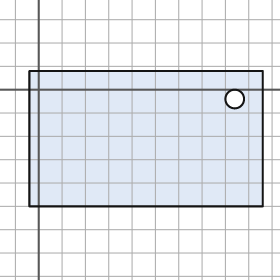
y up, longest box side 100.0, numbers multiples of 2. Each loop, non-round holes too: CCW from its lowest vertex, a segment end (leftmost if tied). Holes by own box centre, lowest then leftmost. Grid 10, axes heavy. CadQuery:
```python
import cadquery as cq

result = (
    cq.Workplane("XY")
    .moveTo(-4.0, -50.0)
    .lineTo(96.0, -50.0)
    .lineTo(96.0, 8.0)
    .lineTo(-4.0, 8.0)
    .close()
    .moveTo(84.0, -4.0)
    .circle(4.0)
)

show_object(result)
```